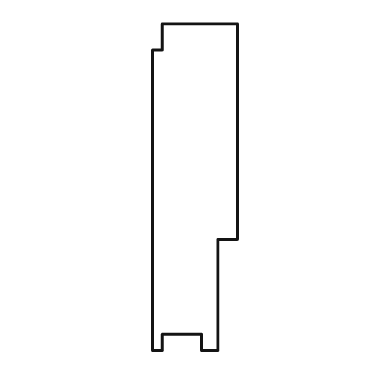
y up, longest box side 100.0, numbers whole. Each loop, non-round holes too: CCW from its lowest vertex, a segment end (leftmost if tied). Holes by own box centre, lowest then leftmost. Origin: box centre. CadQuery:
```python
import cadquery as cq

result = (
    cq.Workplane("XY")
    .moveTo(-13.0, -50.0)
    .lineTo(-10.0, -50.0)
    .lineTo(-10.0, -45.0)
    .lineTo(2.0, -45.0)
    .lineTo(2.0, -50.0)
    .lineTo(7.0, -50.0)
    .lineTo(7.0, -16.0)
    .lineTo(13.0, -16.0)
    .lineTo(13.0, 50.0)
    .lineTo(-10.0, 50.0)
    .lineTo(-10.0, 42.0)
    .lineTo(-13.0, 42.0)
    .close()
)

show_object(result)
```